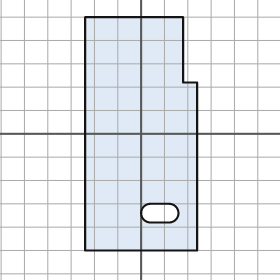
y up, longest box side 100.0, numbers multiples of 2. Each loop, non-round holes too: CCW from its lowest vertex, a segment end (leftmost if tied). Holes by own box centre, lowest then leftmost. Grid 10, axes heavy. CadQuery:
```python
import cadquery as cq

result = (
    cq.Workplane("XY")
    .moveTo(-24.0, -50.0)
    .lineTo(24.0, -50.0)
    .lineTo(24.0, 22.0)
    .lineTo(18.0, 22.0)
    .lineTo(18.0, 50.0)
    .lineTo(-24.0, 50.0)
    .close()
    .moveTo(4.0, -38.0)
    .lineTo(12.0, -38.0)
    .threePointArc((16.0, -34.0), (12.0, -30.0))
    .lineTo(4.0, -30.0)
    .threePointArc((0.0, -34.0), (4.0, -38.0))
    .close()
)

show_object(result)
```